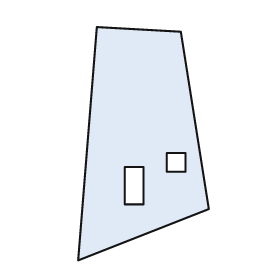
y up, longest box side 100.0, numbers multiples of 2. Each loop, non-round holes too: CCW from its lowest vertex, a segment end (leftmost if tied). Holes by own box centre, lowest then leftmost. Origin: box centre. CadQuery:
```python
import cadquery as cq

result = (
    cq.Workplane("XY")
    .moveTo(-28.0, -50.0)
    .lineTo(28.0, -28.0)
    .lineTo(16.0, 48.0)
    .lineTo(-20.0, 50.0)
    .close()
    .moveTo(-8.0, -26.0)
    .lineTo(0.0, -26.0)
    .lineTo(0.0, -10.0)
    .lineTo(-8.0, -10.0)
    .close()
    .moveTo(10.0, -12.0)
    .lineTo(18.0, -12.0)
    .lineTo(18.0, -4.0)
    .lineTo(10.0, -4.0)
    .close()
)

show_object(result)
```